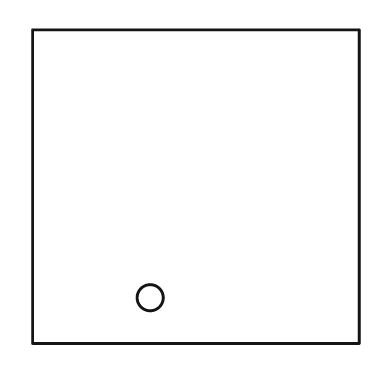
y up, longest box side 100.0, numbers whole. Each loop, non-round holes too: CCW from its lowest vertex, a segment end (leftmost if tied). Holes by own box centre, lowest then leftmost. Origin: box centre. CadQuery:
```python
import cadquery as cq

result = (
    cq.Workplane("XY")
    .moveTo(-50.0, -48.0)
    .lineTo(50.0, -48.0)
    .lineTo(50.0, 48.0)
    .lineTo(-50.0, 48.0)
    .close()
    .moveTo(-14.0, -34.0)
    .circle(4.0)
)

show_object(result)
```